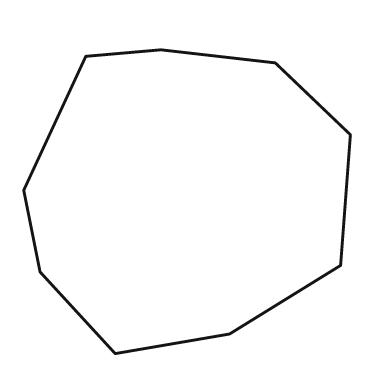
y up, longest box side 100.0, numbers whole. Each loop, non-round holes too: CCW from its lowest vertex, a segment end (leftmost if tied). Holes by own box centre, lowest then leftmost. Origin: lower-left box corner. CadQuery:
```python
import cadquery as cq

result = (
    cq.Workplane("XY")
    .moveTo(28.0, 0.0)
    .lineTo(63.0, 6.0)
    .lineTo(97.0, 27.0)
    .lineTo(100.0, 67.0)
    .lineTo(77.0, 89.0)
    .lineTo(42.0, 93.0)
    .lineTo(19.0, 91.0)
    .lineTo(0.0, 50.0)
    .lineTo(5.0, 25.0)
    .close()
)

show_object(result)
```